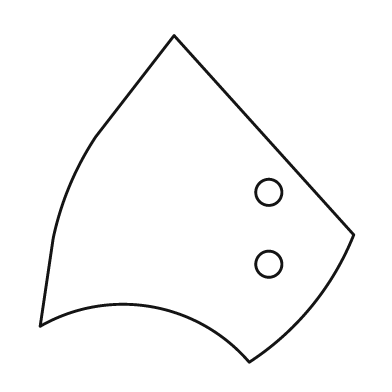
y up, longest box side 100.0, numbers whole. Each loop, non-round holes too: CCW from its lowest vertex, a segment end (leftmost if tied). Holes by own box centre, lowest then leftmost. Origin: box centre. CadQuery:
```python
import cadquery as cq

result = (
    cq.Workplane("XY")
    .moveTo(16.0, -50.0)
    .threePointArc((35.0, -33.0), (48.0, -11.0))
    .lineTo(-7.0, 50.0)
    .lineTo(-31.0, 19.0)
    .threePointArc((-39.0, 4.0), (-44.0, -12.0))
    .lineTo(-48.0, -39.0)
    .threePointArc((-14.0, -33.0), (16.0, -50.0))
    .close()
    .moveTo(22.0, -20.0)
    .circle(4.0)
    .moveTo(22.0, 2.0)
    .circle(4.0)
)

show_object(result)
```